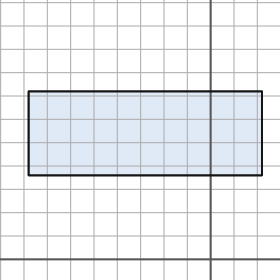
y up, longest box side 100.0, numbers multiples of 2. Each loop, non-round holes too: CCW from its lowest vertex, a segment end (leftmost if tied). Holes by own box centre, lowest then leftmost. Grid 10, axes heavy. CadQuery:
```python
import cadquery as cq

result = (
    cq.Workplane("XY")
    .moveTo(-78.0, 36.0)
    .lineTo(22.0, 36.0)
    .lineTo(22.0, 72.0)
    .lineTo(-78.0, 72.0)
    .close()
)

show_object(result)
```